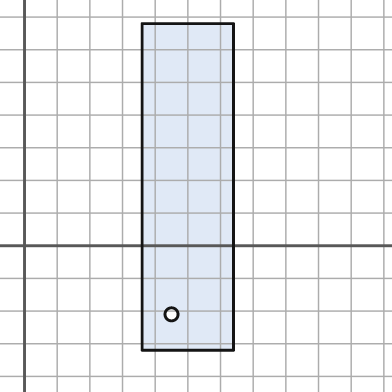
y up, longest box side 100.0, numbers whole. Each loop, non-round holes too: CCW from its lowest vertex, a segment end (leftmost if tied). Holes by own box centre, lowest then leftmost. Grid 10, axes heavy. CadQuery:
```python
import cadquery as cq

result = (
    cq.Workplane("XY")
    .moveTo(36.0, -32.0)
    .lineTo(64.0, -32.0)
    .lineTo(64.0, 68.0)
    .lineTo(36.0, 68.0)
    .close()
    .moveTo(45.0, -21.0)
    .circle(2.0)
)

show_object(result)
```